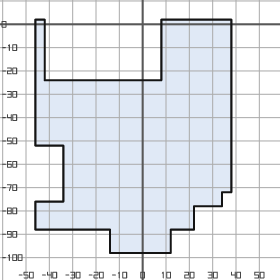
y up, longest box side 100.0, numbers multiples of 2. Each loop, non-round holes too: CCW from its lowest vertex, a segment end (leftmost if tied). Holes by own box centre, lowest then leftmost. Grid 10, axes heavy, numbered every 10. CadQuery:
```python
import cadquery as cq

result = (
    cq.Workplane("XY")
    .moveTo(-14.0, -98.0)
    .lineTo(12.0, -98.0)
    .lineTo(12.0, -88.0)
    .lineTo(22.0, -88.0)
    .lineTo(22.0, -78.0)
    .lineTo(34.0, -78.0)
    .lineTo(34.0, -72.0)
    .lineTo(38.0, -72.0)
    .lineTo(38.0, 2.0)
    .lineTo(8.0, 2.0)
    .lineTo(8.0, -24.0)
    .lineTo(-42.0, -24.0)
    .lineTo(-42.0, 2.0)
    .lineTo(-46.0, 2.0)
    .lineTo(-46.0, -52.0)
    .lineTo(-34.0, -52.0)
    .lineTo(-34.0, -76.0)
    .lineTo(-46.0, -76.0)
    .lineTo(-46.0, -88.0)
    .lineTo(-14.0, -88.0)
    .close()
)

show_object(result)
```